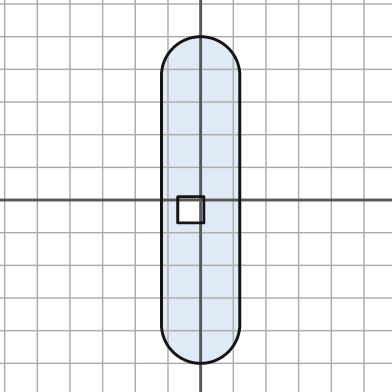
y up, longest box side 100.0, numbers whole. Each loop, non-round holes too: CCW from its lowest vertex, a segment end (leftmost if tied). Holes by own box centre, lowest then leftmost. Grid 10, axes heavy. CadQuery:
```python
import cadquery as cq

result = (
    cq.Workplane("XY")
    .moveTo(-12.0, -38.0)
    .threePointArc((0.0, -50.0), (12.0, -38.0))
    .lineTo(12.0, 38.0)
    .threePointArc((0.0, 50.0), (-12.0, 38.0))
    .close()
    .moveTo(-7.0, -7.0)
    .lineTo(1.0, -7.0)
    .lineTo(1.0, 1.0)
    .lineTo(-7.0, 1.0)
    .close()
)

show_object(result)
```